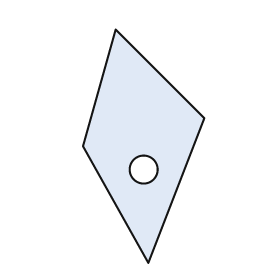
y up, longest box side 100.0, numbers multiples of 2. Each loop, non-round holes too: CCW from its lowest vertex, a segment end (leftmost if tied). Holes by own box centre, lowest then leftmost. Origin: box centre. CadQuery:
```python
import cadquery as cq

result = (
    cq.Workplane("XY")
    .moveTo(2.0, -50.0)
    .lineTo(26.0, 12.0)
    .lineTo(-12.0, 50.0)
    .lineTo(-26.0, 0.0)
    .close()
    .moveTo(0.0, -10.0)
    .circle(6.0)
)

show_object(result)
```